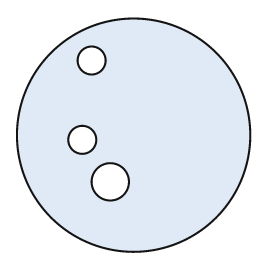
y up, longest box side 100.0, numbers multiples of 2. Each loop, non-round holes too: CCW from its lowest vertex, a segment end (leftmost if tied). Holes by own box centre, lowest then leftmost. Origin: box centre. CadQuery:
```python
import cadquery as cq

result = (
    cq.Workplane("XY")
    .moveTo(0.0, 0.0)
    .circle(50.0)
    .moveTo(-10.0, -20.0)
    .circle(8.0)
    .moveTo(-22.0, -2.0)
    .circle(6.0)
    .moveTo(-18.0, 32.0)
    .circle(6.0)
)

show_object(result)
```